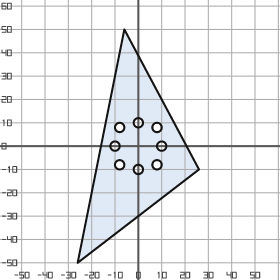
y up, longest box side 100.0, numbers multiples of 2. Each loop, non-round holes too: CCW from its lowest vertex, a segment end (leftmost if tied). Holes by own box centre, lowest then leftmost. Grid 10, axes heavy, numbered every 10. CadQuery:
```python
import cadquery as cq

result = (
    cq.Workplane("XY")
    .moveTo(-26.0, -50.0)
    .lineTo(26.0, -10.0)
    .lineTo(-6.0, 50.0)
    .close()
    .moveTo(0.0, -10.0)
    .circle(2.0)
    .moveTo(-8.0, -8.0)
    .circle(2.0)
    .moveTo(8.0, -8.0)
    .circle(2.0)
    .moveTo(-10.0, 0.0)
    .circle(2.0)
    .moveTo(10.0, 0.0)
    .circle(2.0)
    .moveTo(-8.0, 8.0)
    .circle(2.0)
    .moveTo(8.0, 8.0)
    .circle(2.0)
    .moveTo(0.0, 10.0)
    .circle(2.0)
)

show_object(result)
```